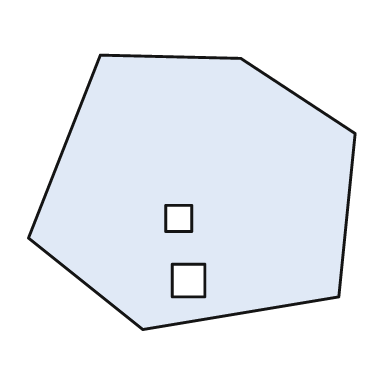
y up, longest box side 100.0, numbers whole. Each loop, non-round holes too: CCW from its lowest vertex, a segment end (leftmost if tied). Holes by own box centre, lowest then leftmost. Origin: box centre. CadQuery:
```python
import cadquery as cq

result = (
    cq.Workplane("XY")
    .moveTo(-15.0, -42.0)
    .lineTo(45.0, -32.0)
    .lineTo(50.0, 18.0)
    .lineTo(15.0, 41.0)
    .lineTo(-28.0, 42.0)
    .lineTo(-50.0, -14.0)
    .close()
    .moveTo(-6.0, -32.0)
    .lineTo(4.0, -32.0)
    .lineTo(4.0, -22.0)
    .lineTo(-6.0, -22.0)
    .close()
    .moveTo(-8.0, -12.0)
    .lineTo(0.0, -12.0)
    .lineTo(0.0, -4.0)
    .lineTo(-8.0, -4.0)
    .close()
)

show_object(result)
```